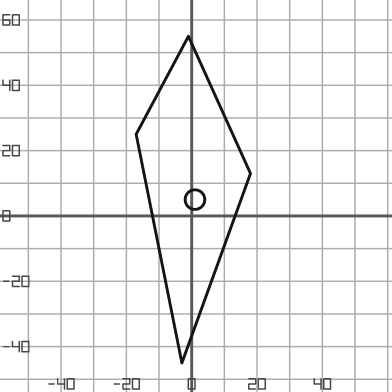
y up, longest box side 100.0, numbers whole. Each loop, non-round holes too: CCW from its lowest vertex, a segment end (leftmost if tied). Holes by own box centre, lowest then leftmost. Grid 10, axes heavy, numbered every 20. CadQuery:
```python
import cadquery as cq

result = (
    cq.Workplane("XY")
    .moveTo(-3.0, -45.0)
    .lineTo(18.0, 13.0)
    .lineTo(-1.0, 55.0)
    .lineTo(-17.0, 25.0)
    .close()
    .moveTo(1.0, 5.0)
    .circle(3.0)
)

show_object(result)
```